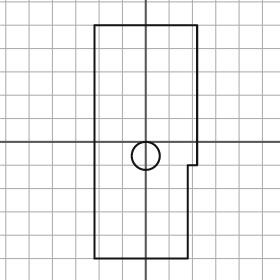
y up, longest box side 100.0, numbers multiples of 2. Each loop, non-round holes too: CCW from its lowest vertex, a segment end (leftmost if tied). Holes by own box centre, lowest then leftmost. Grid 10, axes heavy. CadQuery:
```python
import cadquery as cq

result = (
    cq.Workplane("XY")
    .moveTo(-22.0, -50.0)
    .lineTo(18.0, -50.0)
    .lineTo(18.0, -10.0)
    .lineTo(22.0, -10.0)
    .lineTo(22.0, 50.0)
    .lineTo(-22.0, 50.0)
    .close()
    .moveTo(0.0, -6.0)
    .circle(6.0)
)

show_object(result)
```